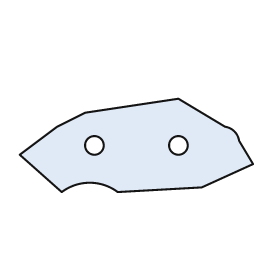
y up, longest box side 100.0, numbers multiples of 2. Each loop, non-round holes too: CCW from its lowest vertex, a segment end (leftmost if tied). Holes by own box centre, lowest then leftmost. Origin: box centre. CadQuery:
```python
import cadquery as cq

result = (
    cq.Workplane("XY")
    .moveTo(-32.0, -20.0)
    .threePointArc((-20.0, -16.0), (-8.0, -20.0))
    .lineTo(28.0, -18.0)
    .lineTo(50.0, -8.0)
    .lineTo(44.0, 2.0)
    .threePointArc((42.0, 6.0), (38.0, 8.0))
    .lineTo(18.0, 20.0)
    .lineTo(-22.0, 14.0)
    .lineTo(-34.0, 8.0)
    .lineTo(-50.0, -4.0)
    .close()
    .moveTo(-18.0, 0.0)
    .circle(4.0)
    .moveTo(18.0, 0.0)
    .circle(4.0)
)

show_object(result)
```